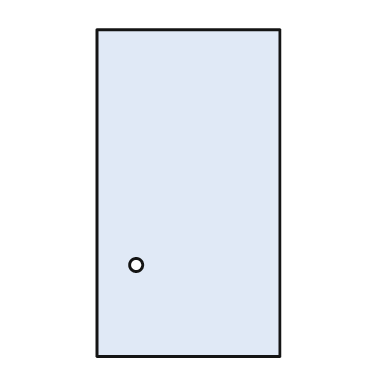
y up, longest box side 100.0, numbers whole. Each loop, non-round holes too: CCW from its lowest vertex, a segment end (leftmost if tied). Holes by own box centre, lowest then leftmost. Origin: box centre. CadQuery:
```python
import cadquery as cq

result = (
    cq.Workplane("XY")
    .moveTo(-28.0, -50.0)
    .lineTo(28.0, -50.0)
    .lineTo(28.0, 50.0)
    .lineTo(-28.0, 50.0)
    .close()
    .moveTo(-16.0, -22.0)
    .circle(2.0)
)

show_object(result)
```